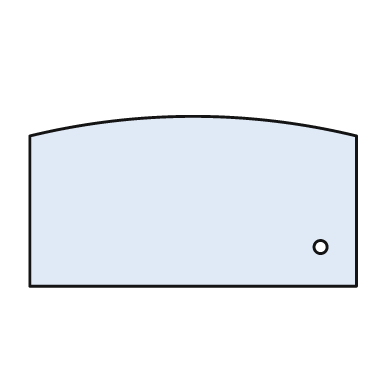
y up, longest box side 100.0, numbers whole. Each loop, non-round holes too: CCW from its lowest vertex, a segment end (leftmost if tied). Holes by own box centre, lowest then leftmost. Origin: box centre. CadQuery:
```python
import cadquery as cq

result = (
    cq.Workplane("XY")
    .moveTo(-50.0, -26.0)
    .lineTo(50.0, -26.0)
    .lineTo(50.0, 20.0)
    .threePointArc((0.0, 26.0), (-50.0, 20.0))
    .close()
    .moveTo(39.0, -14.0)
    .circle(2.0)
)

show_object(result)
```